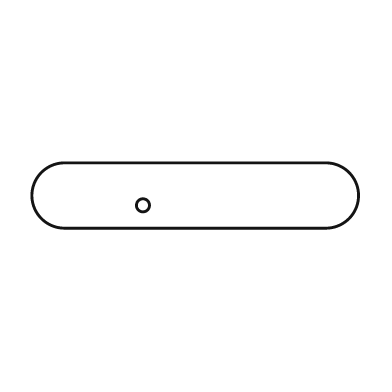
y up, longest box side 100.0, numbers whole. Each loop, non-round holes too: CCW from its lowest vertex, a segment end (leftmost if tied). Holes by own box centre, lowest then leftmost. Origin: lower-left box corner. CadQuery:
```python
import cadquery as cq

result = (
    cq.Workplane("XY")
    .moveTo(10.0, 0.0)
    .lineTo(90.0, 0.0)
    .threePointArc((100.0, 10.0), (90.0, 20.0))
    .lineTo(10.0, 20.0)
    .threePointArc((0.0, 10.0), (10.0, 0.0))
    .close()
    .moveTo(34.0, 7.0)
    .circle(2.0)
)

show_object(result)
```